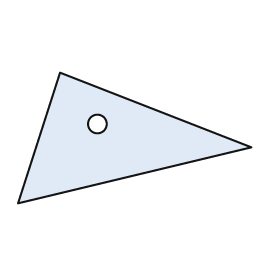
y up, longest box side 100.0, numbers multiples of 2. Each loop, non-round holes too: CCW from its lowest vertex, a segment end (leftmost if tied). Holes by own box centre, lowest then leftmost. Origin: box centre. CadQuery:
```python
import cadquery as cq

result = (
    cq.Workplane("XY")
    .moveTo(-50.0, -28.0)
    .lineTo(50.0, -4.0)
    .lineTo(-32.0, 28.0)
    .close()
    .moveTo(-16.0, 6.0)
    .circle(4.0)
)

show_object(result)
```